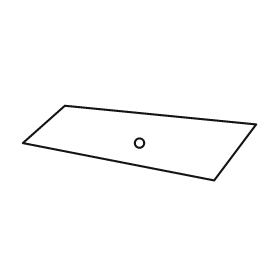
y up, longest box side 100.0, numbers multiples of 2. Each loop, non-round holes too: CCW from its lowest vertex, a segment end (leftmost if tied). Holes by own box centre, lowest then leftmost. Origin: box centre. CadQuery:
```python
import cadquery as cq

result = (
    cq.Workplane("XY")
    .moveTo(32.0, -16.0)
    .lineTo(50.0, 8.0)
    .lineTo(-32.0, 16.0)
    .lineTo(-50.0, 0.0)
    .close()
    .moveTo(0.0, 0.0)
    .circle(2.0)
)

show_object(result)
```